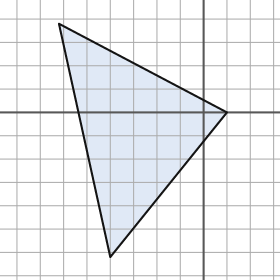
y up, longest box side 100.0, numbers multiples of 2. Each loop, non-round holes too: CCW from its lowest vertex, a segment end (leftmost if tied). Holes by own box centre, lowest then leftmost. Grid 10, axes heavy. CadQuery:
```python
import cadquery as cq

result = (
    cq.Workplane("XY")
    .moveTo(-40.0, -62.0)
    .lineTo(10.0, 0.0)
    .lineTo(-62.0, 38.0)
    .close()
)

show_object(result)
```